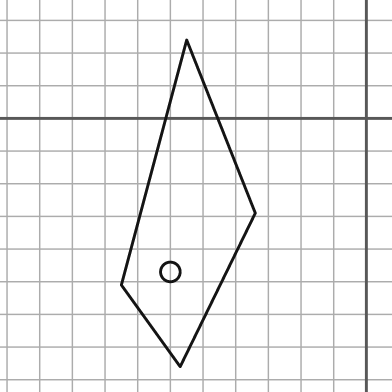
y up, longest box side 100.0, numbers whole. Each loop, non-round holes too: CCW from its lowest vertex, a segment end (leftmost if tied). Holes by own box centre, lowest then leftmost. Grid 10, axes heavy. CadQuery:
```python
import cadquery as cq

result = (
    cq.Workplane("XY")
    .moveTo(-57.0, -76.0)
    .lineTo(-34.0, -29.0)
    .lineTo(-55.0, 24.0)
    .lineTo(-75.0, -51.0)
    .close()
    .moveTo(-60.0, -47.0)
    .circle(3.0)
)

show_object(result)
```